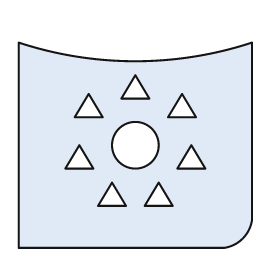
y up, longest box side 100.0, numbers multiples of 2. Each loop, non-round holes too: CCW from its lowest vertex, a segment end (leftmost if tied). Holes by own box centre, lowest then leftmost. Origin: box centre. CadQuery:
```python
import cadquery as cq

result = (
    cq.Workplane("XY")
    .moveTo(-50.0, -44.0)
    .lineTo(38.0, -44.0)
    .threePointArc((46.0, -40.0), (50.0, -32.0))
    .lineTo(50.0, 44.0)
    .threePointArc((0.0, 36.0), (-50.0, 44.0))
    .close()
    .moveTo(-16.0, -26.0)
    .lineTo(-4.0, -26.0)
    .lineTo(-10.0, -16.0)
    .close()
    .moveTo(4.0, -26.0)
    .lineTo(16.0, -26.0)
    .lineTo(10.0, -16.0)
    .close()
    .moveTo(-30.0, -10.0)
    .lineTo(-18.0, -10.0)
    .lineTo(-24.0, 0.0)
    .close()
    .moveTo(18.0, -10.0)
    .lineTo(30.0, -10.0)
    .lineTo(24.0, 0.0)
    .close()
    .moveTo(0.0, 0.0)
    .circle(10.0)
    .moveTo(-26.0, 12.0)
    .lineTo(-14.0, 12.0)
    .lineTo(-20.0, 22.0)
    .close()
    .moveTo(14.0, 12.0)
    .lineTo(26.0, 12.0)
    .lineTo(20.0, 22.0)
    .close()
    .moveTo(-6.0, 20.0)
    .lineTo(6.0, 20.0)
    .lineTo(0.0, 30.0)
    .close()
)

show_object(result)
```